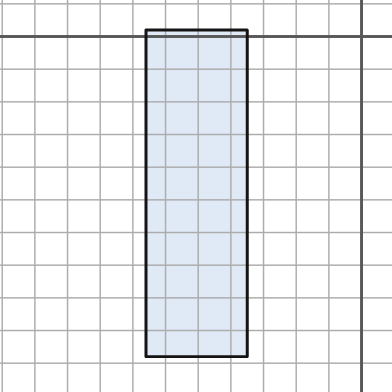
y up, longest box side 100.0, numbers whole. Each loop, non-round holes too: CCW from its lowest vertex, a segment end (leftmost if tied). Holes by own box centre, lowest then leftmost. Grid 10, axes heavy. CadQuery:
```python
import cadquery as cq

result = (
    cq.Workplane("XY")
    .moveTo(-66.0, -98.0)
    .lineTo(-35.0, -98.0)
    .lineTo(-35.0, 2.0)
    .lineTo(-66.0, 2.0)
    .close()
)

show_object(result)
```